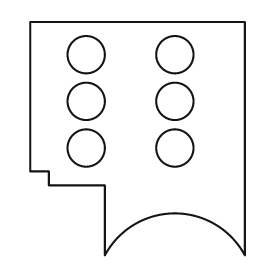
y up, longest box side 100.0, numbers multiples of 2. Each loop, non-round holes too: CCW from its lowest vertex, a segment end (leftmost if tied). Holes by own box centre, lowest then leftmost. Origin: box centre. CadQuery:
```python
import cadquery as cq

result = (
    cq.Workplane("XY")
    .moveTo(-14.0, -50.0)
    .threePointArc((16.0, -32.0), (46.0, -50.0))
    .lineTo(46.0, 50.0)
    .lineTo(-46.0, 50.0)
    .lineTo(-46.0, -14.0)
    .lineTo(-38.0, -14.0)
    .lineTo(-38.0, -20.0)
    .lineTo(-14.0, -20.0)
    .close()
    .moveTo(-22.0, -4.0)
    .circle(8.0)
    .moveTo(16.0, -4.0)
    .circle(8.0)
    .moveTo(-22.0, 16.0)
    .circle(8.0)
    .moveTo(16.0, 16.0)
    .circle(8.0)
    .moveTo(-22.0, 36.0)
    .circle(8.0)
    .moveTo(16.0, 36.0)
    .circle(8.0)
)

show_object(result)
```